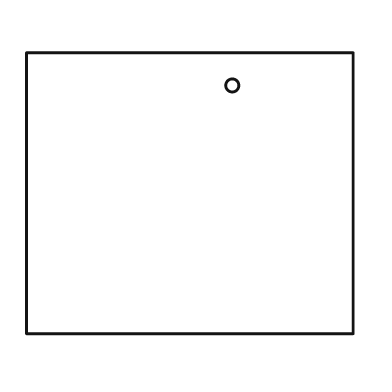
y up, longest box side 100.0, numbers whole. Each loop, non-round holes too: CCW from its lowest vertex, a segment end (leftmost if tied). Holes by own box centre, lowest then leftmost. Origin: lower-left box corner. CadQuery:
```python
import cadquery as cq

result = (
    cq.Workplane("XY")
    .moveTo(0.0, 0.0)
    .lineTo(100.0, 0.0)
    .lineTo(100.0, 86.0)
    .lineTo(0.0, 86.0)
    .close()
    .moveTo(63.0, 76.0)
    .circle(2.0)
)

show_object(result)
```